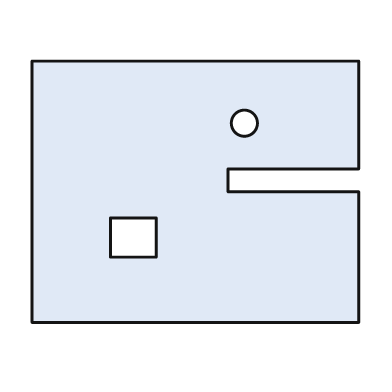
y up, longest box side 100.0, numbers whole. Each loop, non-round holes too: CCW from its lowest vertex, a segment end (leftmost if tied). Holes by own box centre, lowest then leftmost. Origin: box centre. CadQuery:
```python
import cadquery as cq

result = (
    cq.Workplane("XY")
    .moveTo(-50.0, -40.0)
    .lineTo(50.0, -40.0)
    .lineTo(50.0, 0.0)
    .lineTo(10.0, 0.0)
    .lineTo(10.0, 7.0)
    .lineTo(50.0, 7.0)
    .lineTo(50.0, 40.0)
    .lineTo(-50.0, 40.0)
    .close()
    .moveTo(-26.0, -20.0)
    .lineTo(-12.0, -20.0)
    .lineTo(-12.0, -8.0)
    .lineTo(-26.0, -8.0)
    .close()
    .moveTo(15.0, 21.0)
    .circle(4.0)
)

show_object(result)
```